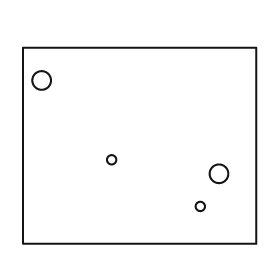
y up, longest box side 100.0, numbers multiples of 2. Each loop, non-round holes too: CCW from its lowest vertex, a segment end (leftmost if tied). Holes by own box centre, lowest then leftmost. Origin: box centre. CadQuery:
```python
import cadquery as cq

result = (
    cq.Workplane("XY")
    .moveTo(-50.0, -42.0)
    .lineTo(50.0, -42.0)
    .lineTo(50.0, 42.0)
    .lineTo(-50.0, 42.0)
    .close()
    .moveTo(26.0, -26.0)
    .circle(2.0)
    .moveTo(34.0, -12.0)
    .circle(4.0)
    .moveTo(-12.0, -6.0)
    .circle(2.0)
    .moveTo(-42.0, 28.0)
    .circle(4.0)
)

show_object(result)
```